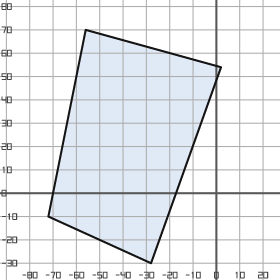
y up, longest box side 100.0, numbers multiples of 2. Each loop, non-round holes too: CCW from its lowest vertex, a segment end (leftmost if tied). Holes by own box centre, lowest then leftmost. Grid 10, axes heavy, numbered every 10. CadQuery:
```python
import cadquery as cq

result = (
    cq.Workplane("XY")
    .moveTo(-28.0, -30.0)
    .lineTo(2.0, 54.0)
    .lineTo(-56.0, 70.0)
    .lineTo(-72.0, -10.0)
    .close()
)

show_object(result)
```